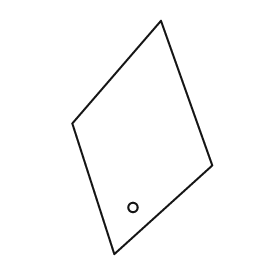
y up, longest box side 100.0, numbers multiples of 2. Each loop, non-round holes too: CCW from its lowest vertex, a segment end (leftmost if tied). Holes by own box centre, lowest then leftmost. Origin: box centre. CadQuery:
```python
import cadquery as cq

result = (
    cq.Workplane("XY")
    .moveTo(-12.0, -50.0)
    .lineTo(30.0, -12.0)
    .lineTo(8.0, 50.0)
    .lineTo(-30.0, 6.0)
    .close()
    .moveTo(-4.0, -30.0)
    .circle(2.0)
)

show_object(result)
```